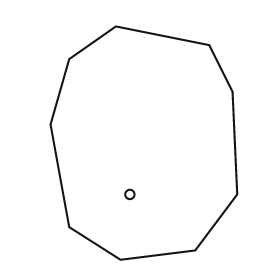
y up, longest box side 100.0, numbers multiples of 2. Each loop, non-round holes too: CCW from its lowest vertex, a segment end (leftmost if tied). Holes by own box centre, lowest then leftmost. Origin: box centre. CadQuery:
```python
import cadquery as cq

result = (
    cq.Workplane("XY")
    .moveTo(-10.0, -50.0)
    .lineTo(22.0, -46.0)
    .lineTo(40.0, -22.0)
    .lineTo(38.0, 22.0)
    .lineTo(28.0, 42.0)
    .lineTo(-12.0, 50.0)
    .lineTo(-32.0, 36.0)
    .lineTo(-40.0, 8.0)
    .lineTo(-32.0, -36.0)
    .close()
    .moveTo(-6.0, -22.0)
    .circle(2.0)
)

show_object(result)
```